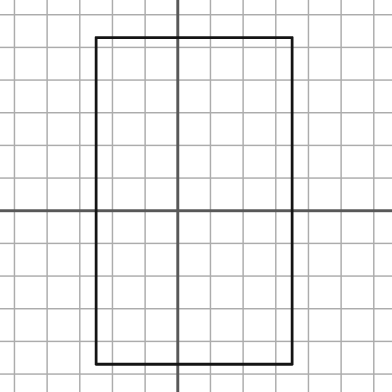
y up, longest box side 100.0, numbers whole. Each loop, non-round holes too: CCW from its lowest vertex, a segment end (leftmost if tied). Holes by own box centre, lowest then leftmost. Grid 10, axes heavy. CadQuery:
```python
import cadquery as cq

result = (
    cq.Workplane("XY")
    .moveTo(-25.0, -47.0)
    .lineTo(35.0, -47.0)
    .lineTo(35.0, 53.0)
    .lineTo(-25.0, 53.0)
    .close()
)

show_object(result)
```